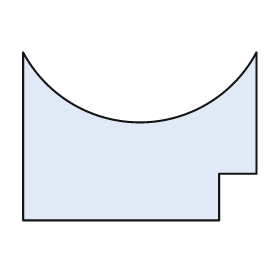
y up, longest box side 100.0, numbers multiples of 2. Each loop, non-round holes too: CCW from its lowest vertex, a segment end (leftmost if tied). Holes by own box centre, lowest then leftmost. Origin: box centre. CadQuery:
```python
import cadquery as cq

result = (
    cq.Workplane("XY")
    .moveTo(-50.0, -36.0)
    .lineTo(34.0, -36.0)
    .lineTo(34.0, -16.0)
    .lineTo(50.0, -16.0)
    .lineTo(50.0, 36.0)
    .threePointArc((0.0, 6.0), (-50.0, 36.0))
    .close()
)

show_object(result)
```